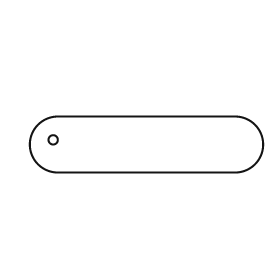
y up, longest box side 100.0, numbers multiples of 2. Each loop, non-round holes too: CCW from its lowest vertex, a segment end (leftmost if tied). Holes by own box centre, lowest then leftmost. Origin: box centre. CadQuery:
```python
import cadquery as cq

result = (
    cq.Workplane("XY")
    .moveTo(-38.0, -12.0)
    .lineTo(38.0, -12.0)
    .threePointArc((50.0, 0.0), (38.0, 12.0))
    .lineTo(-38.0, 12.0)
    .threePointArc((-50.0, 0.0), (-38.0, -12.0))
    .close()
    .moveTo(-40.0, 2.0)
    .circle(2.0)
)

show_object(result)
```